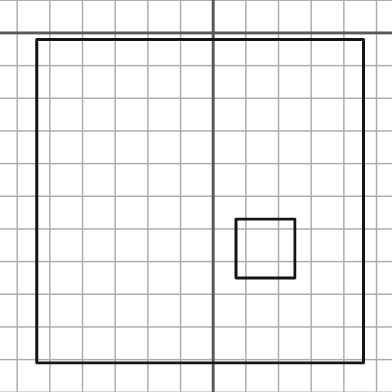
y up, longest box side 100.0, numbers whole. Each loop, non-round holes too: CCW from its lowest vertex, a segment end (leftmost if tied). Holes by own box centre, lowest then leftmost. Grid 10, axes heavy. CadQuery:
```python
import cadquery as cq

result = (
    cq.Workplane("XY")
    .moveTo(-54.0, -101.0)
    .lineTo(46.0, -101.0)
    .lineTo(46.0, -2.0)
    .lineTo(-54.0, -2.0)
    .close()
    .moveTo(7.0, -75.0)
    .lineTo(25.0, -75.0)
    .lineTo(25.0, -57.0)
    .lineTo(7.0, -57.0)
    .close()
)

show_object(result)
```